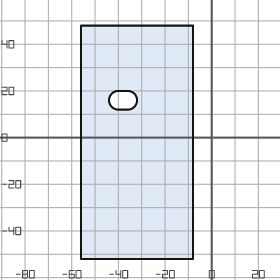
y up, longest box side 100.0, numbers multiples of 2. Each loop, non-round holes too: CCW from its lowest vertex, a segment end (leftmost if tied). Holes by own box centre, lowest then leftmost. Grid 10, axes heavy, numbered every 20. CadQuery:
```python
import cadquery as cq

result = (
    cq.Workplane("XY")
    .moveTo(-56.0, -52.0)
    .lineTo(-8.0, -52.0)
    .lineTo(-8.0, 48.0)
    .lineTo(-56.0, 48.0)
    .close()
    .moveTo(-40.0, 12.0)
    .lineTo(-36.0, 12.0)
    .threePointArc((-32.0, 16.0), (-36.0, 20.0))
    .lineTo(-40.0, 20.0)
    .threePointArc((-44.0, 16.0), (-40.0, 12.0))
    .close()
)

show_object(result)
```